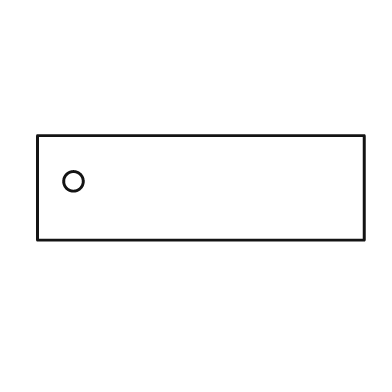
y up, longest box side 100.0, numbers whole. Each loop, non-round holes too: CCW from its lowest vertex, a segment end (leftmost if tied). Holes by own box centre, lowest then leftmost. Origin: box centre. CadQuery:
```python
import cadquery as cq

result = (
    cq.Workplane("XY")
    .moveTo(-50.0, -16.0)
    .lineTo(50.0, -16.0)
    .lineTo(50.0, 16.0)
    .lineTo(-50.0, 16.0)
    .close()
    .moveTo(-39.0, 2.0)
    .circle(3.0)
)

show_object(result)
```